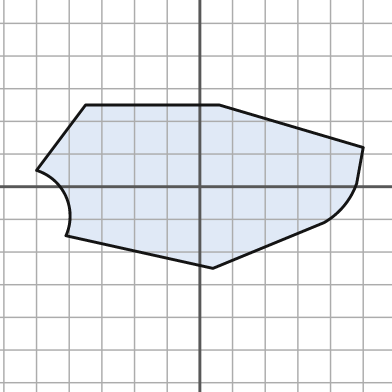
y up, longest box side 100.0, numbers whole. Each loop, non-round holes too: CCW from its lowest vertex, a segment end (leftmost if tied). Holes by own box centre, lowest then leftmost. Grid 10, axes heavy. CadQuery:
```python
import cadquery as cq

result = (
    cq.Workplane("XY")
    .moveTo(4.0, -25.0)
    .lineTo(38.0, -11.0)
    .threePointArc((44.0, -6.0), (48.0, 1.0))
    .lineTo(50.0, 12.0)
    .lineTo(6.0, 25.0)
    .lineTo(-35.0, 25.0)
    .lineTo(-50.0, 5.0)
    .threePointArc((-41.0, -3.0), (-41.0, -15.0))
    .close()
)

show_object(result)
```